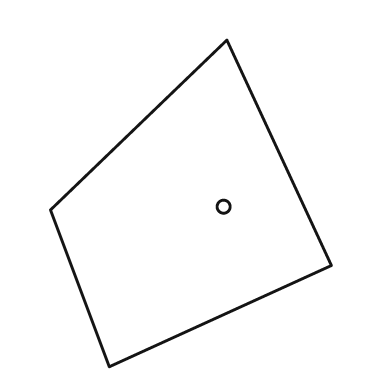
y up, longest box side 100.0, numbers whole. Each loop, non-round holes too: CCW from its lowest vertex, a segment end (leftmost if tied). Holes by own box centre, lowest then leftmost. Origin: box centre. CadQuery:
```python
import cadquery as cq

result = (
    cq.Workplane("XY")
    .moveTo(-25.0, -50.0)
    .lineTo(43.0, -19.0)
    .lineTo(11.0, 50.0)
    .lineTo(-43.0, -2.0)
    .close()
    .moveTo(10.0, -1.0)
    .circle(2.0)
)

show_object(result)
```